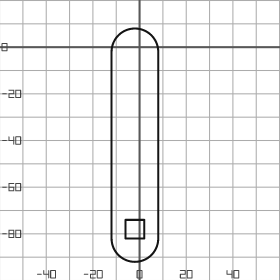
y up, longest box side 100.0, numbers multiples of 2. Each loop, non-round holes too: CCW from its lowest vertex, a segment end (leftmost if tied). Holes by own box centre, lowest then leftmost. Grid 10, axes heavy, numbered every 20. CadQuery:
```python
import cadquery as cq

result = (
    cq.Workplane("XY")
    .moveTo(-12.0, -82.0)
    .threePointArc((-2.0, -92.0), (8.0, -82.0))
    .lineTo(8.0, -2.0)
    .threePointArc((-2.0, 8.0), (-12.0, -2.0))
    .close()
    .moveTo(-6.0, -82.0)
    .lineTo(2.0, -82.0)
    .lineTo(2.0, -74.0)
    .lineTo(-6.0, -74.0)
    .close()
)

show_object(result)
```